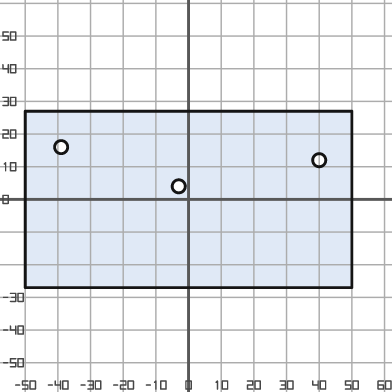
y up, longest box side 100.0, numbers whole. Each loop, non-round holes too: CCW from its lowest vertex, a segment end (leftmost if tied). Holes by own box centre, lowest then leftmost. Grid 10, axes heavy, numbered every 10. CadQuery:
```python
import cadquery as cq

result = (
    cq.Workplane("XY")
    .moveTo(-50.0, -27.0)
    .lineTo(50.0, -27.0)
    .lineTo(50.0, 27.0)
    .lineTo(-50.0, 27.0)
    .close()
    .moveTo(-3.0, 4.0)
    .circle(2.0)
    .moveTo(40.0, 12.0)
    .circle(2.0)
    .moveTo(-39.0, 16.0)
    .circle(2.0)
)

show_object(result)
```